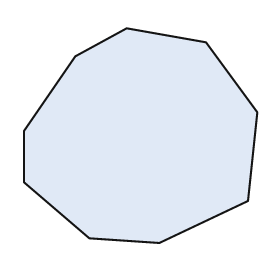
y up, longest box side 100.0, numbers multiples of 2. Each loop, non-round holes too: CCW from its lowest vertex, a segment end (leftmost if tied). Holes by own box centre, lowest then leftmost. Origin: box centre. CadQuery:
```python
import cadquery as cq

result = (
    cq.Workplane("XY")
    .moveTo(8.0, -46.0)
    .lineTo(46.0, -28.0)
    .lineTo(50.0, 10.0)
    .lineTo(28.0, 40.0)
    .lineTo(-6.0, 46.0)
    .lineTo(-28.0, 34.0)
    .lineTo(-50.0, 2.0)
    .lineTo(-50.0, -20.0)
    .lineTo(-22.0, -44.0)
    .close()
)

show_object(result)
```